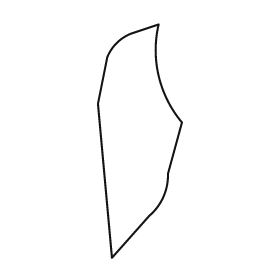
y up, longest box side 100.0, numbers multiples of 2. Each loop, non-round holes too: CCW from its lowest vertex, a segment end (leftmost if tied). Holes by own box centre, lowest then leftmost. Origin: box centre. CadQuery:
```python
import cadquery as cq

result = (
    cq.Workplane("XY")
    .moveTo(-12.0, -50.0)
    .lineTo(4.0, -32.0)
    .threePointArc((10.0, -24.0), (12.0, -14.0))
    .lineTo(18.0, 8.0)
    .threePointArc((8.0, 28.0), (8.0, 50.0))
    .lineTo(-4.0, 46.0)
    .threePointArc((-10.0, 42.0), (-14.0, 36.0))
    .lineTo(-18.0, 16.0)
    .close()
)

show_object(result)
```